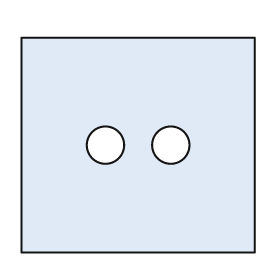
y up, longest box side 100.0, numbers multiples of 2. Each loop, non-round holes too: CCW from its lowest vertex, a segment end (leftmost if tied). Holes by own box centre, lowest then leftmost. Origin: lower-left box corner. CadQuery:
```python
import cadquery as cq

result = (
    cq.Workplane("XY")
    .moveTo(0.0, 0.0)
    .lineTo(100.0, 0.0)
    .lineTo(100.0, 92.0)
    .lineTo(0.0, 92.0)
    .close()
    .moveTo(36.0, 46.0)
    .circle(8.0)
    .moveTo(64.0, 46.0)
    .circle(8.0)
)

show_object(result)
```